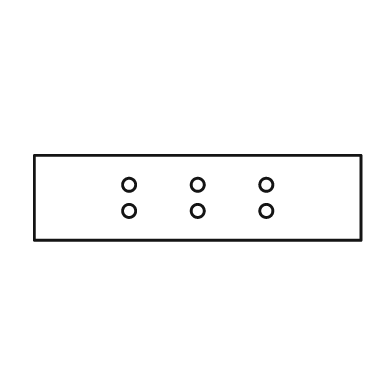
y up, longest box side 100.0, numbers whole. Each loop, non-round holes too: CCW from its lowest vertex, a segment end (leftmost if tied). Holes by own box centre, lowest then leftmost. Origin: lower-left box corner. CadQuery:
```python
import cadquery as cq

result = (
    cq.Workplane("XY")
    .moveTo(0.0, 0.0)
    .lineTo(100.0, 0.0)
    .lineTo(100.0, 26.0)
    .lineTo(0.0, 26.0)
    .close()
    .moveTo(29.0, 9.0)
    .circle(2.0)
    .moveTo(50.0, 9.0)
    .circle(2.0)
    .moveTo(71.0, 9.0)
    .circle(2.0)
    .moveTo(29.0, 17.0)
    .circle(2.0)
    .moveTo(50.0, 17.0)
    .circle(2.0)
    .moveTo(71.0, 17.0)
    .circle(2.0)
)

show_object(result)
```